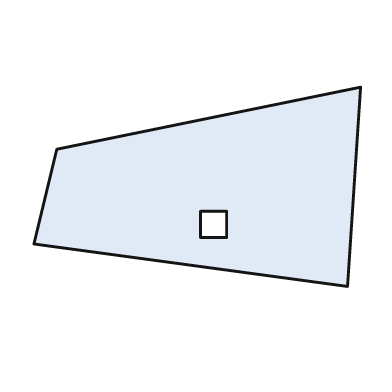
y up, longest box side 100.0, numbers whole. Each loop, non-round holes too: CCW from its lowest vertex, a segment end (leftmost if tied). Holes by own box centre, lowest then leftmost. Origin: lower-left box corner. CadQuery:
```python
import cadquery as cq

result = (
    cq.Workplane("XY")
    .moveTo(96.0, 0.0)
    .lineTo(100.0, 61.0)
    .lineTo(7.0, 42.0)
    .lineTo(0.0, 13.0)
    .close()
    .moveTo(51.0, 15.0)
    .lineTo(59.0, 15.0)
    .lineTo(59.0, 23.0)
    .lineTo(51.0, 23.0)
    .close()
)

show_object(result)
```